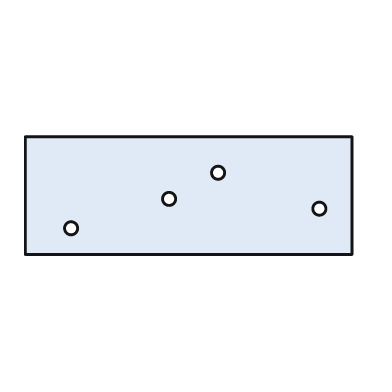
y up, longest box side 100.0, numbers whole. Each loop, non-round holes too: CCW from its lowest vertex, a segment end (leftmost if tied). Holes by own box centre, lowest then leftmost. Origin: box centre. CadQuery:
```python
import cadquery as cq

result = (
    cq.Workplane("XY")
    .moveTo(-50.0, -18.0)
    .lineTo(50.0, -18.0)
    .lineTo(50.0, 18.0)
    .lineTo(-50.0, 18.0)
    .close()
    .moveTo(-36.0, -10.0)
    .circle(2.0)
    .moveTo(40.0, -4.0)
    .circle(2.0)
    .moveTo(-6.0, -1.0)
    .circle(2.0)
    .moveTo(9.0, 7.0)
    .circle(2.0)
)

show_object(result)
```